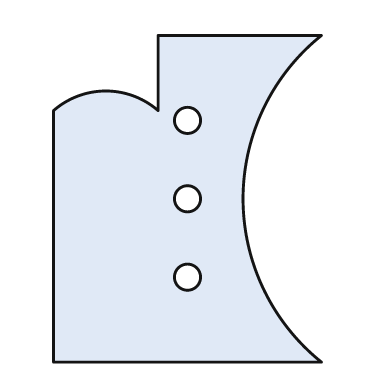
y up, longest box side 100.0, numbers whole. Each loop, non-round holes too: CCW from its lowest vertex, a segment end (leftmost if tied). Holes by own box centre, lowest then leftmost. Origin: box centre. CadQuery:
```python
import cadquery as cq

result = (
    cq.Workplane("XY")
    .moveTo(-41.0, -50.0)
    .lineTo(41.0, -50.0)
    .threePointArc((17.0, 0.0), (41.0, 50.0))
    .lineTo(-9.0, 50.0)
    .lineTo(-9.0, 27.0)
    .threePointArc((-25.0, 33.0), (-41.0, 27.0))
    .close()
    .moveTo(0.0, -24.0)
    .circle(4.0)
    .moveTo(0.0, 0.0)
    .circle(4.0)
    .moveTo(0.0, 24.0)
    .circle(4.0)
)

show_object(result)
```